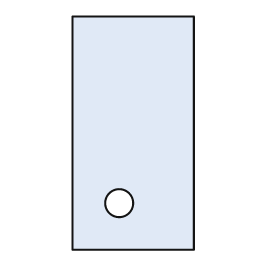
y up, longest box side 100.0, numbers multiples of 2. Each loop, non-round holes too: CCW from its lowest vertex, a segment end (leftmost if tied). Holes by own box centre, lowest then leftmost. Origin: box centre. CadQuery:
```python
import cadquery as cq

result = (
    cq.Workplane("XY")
    .moveTo(-26.0, -50.0)
    .lineTo(26.0, -50.0)
    .lineTo(26.0, 50.0)
    .lineTo(-26.0, 50.0)
    .close()
    .moveTo(-6.0, -30.0)
    .circle(6.0)
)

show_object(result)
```